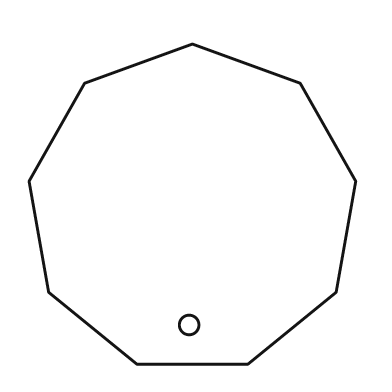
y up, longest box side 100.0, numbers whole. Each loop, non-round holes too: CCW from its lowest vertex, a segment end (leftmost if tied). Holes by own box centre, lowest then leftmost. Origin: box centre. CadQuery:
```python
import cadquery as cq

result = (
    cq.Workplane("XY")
    .moveTo(-17.0, -49.0)
    .lineTo(17.0, -49.0)
    .lineTo(44.0, -27.0)
    .lineTo(50.0, 7.0)
    .lineTo(33.0, 37.0)
    .lineTo(0.0, 49.0)
    .lineTo(-33.0, 37.0)
    .lineTo(-50.0, 7.0)
    .lineTo(-44.0, -27.0)
    .close()
    .moveTo(-1.0, -37.0)
    .circle(3.0)
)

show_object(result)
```